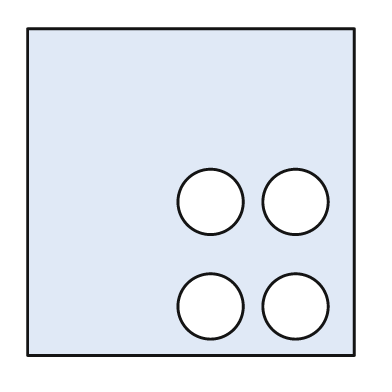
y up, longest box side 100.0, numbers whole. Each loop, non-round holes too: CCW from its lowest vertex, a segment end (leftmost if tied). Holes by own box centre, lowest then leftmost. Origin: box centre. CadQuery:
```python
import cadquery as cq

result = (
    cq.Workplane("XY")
    .moveTo(-50.0, -50.0)
    .lineTo(50.0, -50.0)
    .lineTo(50.0, 50.0)
    .lineTo(-50.0, 50.0)
    .close()
    .moveTo(6.0, -35.0)
    .circle(10.0)
    .moveTo(32.0, -35.0)
    .circle(10.0)
    .moveTo(6.0, -3.0)
    .circle(10.0)
    .moveTo(32.0, -3.0)
    .circle(10.0)
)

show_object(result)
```